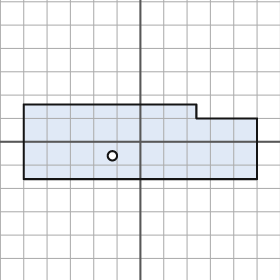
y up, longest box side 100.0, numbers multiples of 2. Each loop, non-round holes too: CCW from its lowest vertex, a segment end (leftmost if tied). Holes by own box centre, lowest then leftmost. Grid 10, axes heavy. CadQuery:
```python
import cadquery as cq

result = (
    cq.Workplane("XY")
    .moveTo(-50.0, -16.0)
    .lineTo(50.0, -16.0)
    .lineTo(50.0, 10.0)
    .lineTo(24.0, 10.0)
    .lineTo(24.0, 16.0)
    .lineTo(-50.0, 16.0)
    .close()
    .moveTo(-12.0, -6.0)
    .circle(2.0)
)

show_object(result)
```